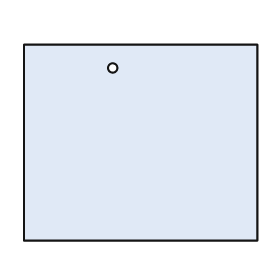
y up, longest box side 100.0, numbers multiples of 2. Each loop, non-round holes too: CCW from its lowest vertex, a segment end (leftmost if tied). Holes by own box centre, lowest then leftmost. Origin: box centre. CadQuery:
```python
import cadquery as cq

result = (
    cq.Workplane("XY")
    .moveTo(-50.0, -42.0)
    .lineTo(50.0, -42.0)
    .lineTo(50.0, 42.0)
    .lineTo(-50.0, 42.0)
    .close()
    .moveTo(-12.0, 32.0)
    .circle(2.0)
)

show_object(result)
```